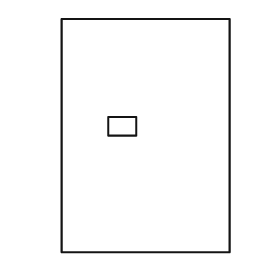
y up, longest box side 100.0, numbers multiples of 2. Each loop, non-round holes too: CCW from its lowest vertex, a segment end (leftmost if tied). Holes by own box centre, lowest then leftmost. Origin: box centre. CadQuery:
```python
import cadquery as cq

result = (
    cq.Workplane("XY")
    .moveTo(-36.0, -50.0)
    .lineTo(36.0, -50.0)
    .lineTo(36.0, 50.0)
    .lineTo(-36.0, 50.0)
    .close()
    .moveTo(-16.0, 0.0)
    .lineTo(-4.0, 0.0)
    .lineTo(-4.0, 8.0)
    .lineTo(-16.0, 8.0)
    .close()
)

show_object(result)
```